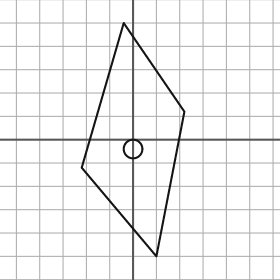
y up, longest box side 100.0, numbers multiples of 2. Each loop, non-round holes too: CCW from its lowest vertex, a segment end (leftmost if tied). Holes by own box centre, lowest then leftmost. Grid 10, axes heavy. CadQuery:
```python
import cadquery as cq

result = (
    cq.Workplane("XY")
    .moveTo(10.0, -50.0)
    .lineTo(22.0, 12.0)
    .lineTo(-4.0, 50.0)
    .lineTo(-22.0, -12.0)
    .close()
    .moveTo(0.0, -4.0)
    .circle(4.0)
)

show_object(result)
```